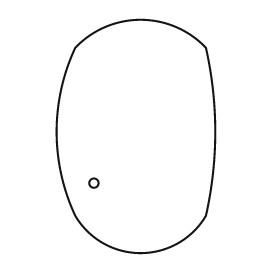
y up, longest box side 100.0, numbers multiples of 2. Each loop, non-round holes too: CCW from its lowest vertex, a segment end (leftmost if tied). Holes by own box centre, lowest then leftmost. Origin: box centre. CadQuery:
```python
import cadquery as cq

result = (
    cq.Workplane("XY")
    .moveTo(-26.0, -34.0)
    .threePointArc((2.0, -50.0), (30.0, -34.0))
    .threePointArc((34.0, 2.0), (30.0, 38.0))
    .threePointArc((2.0, 50.0), (-26.0, 38.0))
    .threePointArc((-34.0, 2.0), (-26.0, -34.0))
    .close()
    .moveTo(-18.0, -20.0)
    .circle(2.0)
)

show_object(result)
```